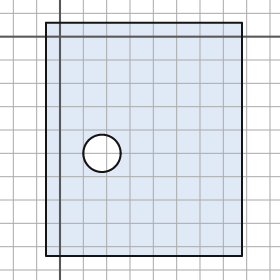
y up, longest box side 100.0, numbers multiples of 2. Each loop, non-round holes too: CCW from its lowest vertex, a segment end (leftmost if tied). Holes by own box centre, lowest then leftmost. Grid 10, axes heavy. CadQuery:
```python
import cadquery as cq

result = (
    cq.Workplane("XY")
    .moveTo(-6.0, -94.0)
    .lineTo(78.0, -94.0)
    .lineTo(78.0, 6.0)
    .lineTo(-6.0, 6.0)
    .close()
    .moveTo(18.0, -50.0)
    .circle(8.0)
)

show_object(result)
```